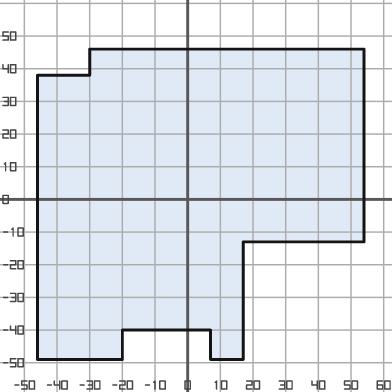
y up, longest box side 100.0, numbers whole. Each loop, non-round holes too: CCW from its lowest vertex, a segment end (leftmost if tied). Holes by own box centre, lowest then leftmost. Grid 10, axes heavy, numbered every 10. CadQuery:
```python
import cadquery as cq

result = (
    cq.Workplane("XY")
    .moveTo(-46.0, -49.0)
    .lineTo(-20.0, -49.0)
    .lineTo(-20.0, -40.0)
    .lineTo(7.0, -40.0)
    .lineTo(7.0, -49.0)
    .lineTo(17.0, -49.0)
    .lineTo(17.0, -13.0)
    .lineTo(54.0, -13.0)
    .lineTo(54.0, 46.0)
    .lineTo(-30.0, 46.0)
    .lineTo(-30.0, 38.0)
    .lineTo(-46.0, 38.0)
    .close()
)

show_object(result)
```